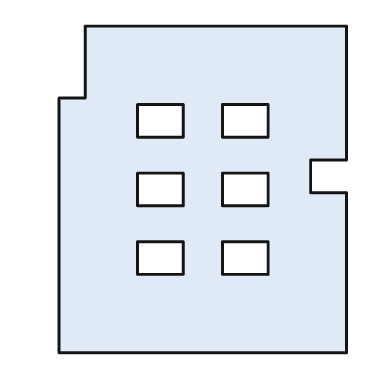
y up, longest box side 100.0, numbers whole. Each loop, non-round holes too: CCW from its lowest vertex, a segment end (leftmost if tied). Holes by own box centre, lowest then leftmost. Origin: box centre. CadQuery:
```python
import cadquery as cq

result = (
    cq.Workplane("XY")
    .moveTo(-44.0, -50.0)
    .lineTo(44.0, -50.0)
    .lineTo(44.0, -1.0)
    .lineTo(33.0, -1.0)
    .lineTo(33.0, 9.0)
    .lineTo(44.0, 9.0)
    .lineTo(44.0, 50.0)
    .lineTo(-36.0, 50.0)
    .lineTo(-36.0, 28.0)
    .lineTo(-44.0, 28.0)
    .close()
    .moveTo(-20.0, -26.0)
    .lineTo(-6.0, -26.0)
    .lineTo(-6.0, -16.0)
    .lineTo(-20.0, -16.0)
    .close()
    .moveTo(6.0, -26.0)
    .lineTo(20.0, -26.0)
    .lineTo(20.0, -16.0)
    .lineTo(6.0, -16.0)
    .close()
    .moveTo(-20.0, -5.0)
    .lineTo(-6.0, -5.0)
    .lineTo(-6.0, 5.0)
    .lineTo(-20.0, 5.0)
    .close()
    .moveTo(6.0, -5.0)
    .lineTo(20.0, -5.0)
    .lineTo(20.0, 5.0)
    .lineTo(6.0, 5.0)
    .close()
    .moveTo(-20.0, 16.0)
    .lineTo(-6.0, 16.0)
    .lineTo(-6.0, 26.0)
    .lineTo(-20.0, 26.0)
    .close()
    .moveTo(6.0, 16.0)
    .lineTo(20.0, 16.0)
    .lineTo(20.0, 26.0)
    .lineTo(6.0, 26.0)
    .close()
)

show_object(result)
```